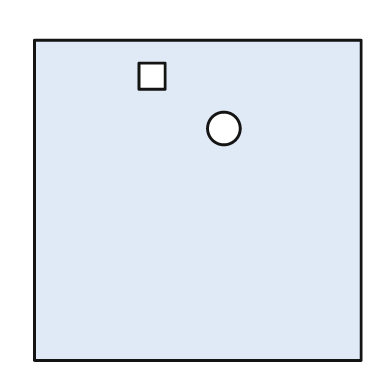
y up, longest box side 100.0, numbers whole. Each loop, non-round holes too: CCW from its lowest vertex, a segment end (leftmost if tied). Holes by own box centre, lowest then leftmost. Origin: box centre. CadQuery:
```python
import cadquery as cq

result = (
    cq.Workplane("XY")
    .moveTo(-50.0, -49.0)
    .lineTo(50.0, -49.0)
    .lineTo(50.0, 49.0)
    .lineTo(-50.0, 49.0)
    .close()
    .moveTo(8.0, 22.0)
    .circle(5.0)
    .moveTo(-18.0, 34.0)
    .lineTo(-10.0, 34.0)
    .lineTo(-10.0, 42.0)
    .lineTo(-18.0, 42.0)
    .close()
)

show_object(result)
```